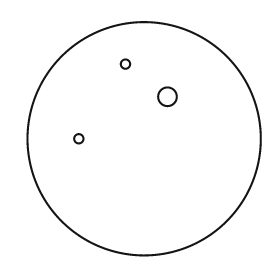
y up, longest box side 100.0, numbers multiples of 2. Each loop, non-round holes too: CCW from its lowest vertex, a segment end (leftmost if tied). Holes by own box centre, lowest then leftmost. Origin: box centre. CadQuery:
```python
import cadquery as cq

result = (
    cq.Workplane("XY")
    .moveTo(0.0, 0.0)
    .circle(50.0)
    .moveTo(-28.0, 0.0)
    .circle(2.0)
    .moveTo(10.0, 18.0)
    .circle(4.0)
    .moveTo(-8.0, 32.0)
    .circle(2.0)
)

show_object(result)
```